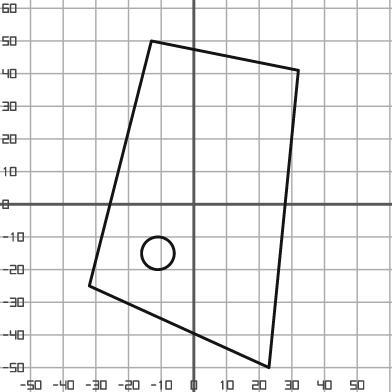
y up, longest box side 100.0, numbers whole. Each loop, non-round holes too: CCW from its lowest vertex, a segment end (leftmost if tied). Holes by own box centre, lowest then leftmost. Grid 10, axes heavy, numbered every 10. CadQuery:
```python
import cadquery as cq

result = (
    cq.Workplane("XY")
    .moveTo(23.0, -50.0)
    .lineTo(32.0, 41.0)
    .lineTo(-13.0, 50.0)
    .lineTo(-32.0, -25.0)
    .close()
    .moveTo(-11.0, -15.0)
    .circle(5.0)
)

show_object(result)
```